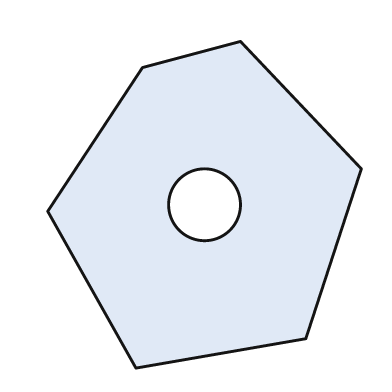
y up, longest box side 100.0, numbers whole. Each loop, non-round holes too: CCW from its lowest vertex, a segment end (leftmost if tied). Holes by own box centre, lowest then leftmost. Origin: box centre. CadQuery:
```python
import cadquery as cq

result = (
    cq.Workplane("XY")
    .moveTo(-21.0, -50.0)
    .lineTo(31.0, -41.0)
    .lineTo(48.0, 11.0)
    .lineTo(11.0, 50.0)
    .lineTo(-19.0, 42.0)
    .lineTo(-48.0, -2.0)
    .close()
    .moveTo(0.0, 0.0)
    .circle(11.0)
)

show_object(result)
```